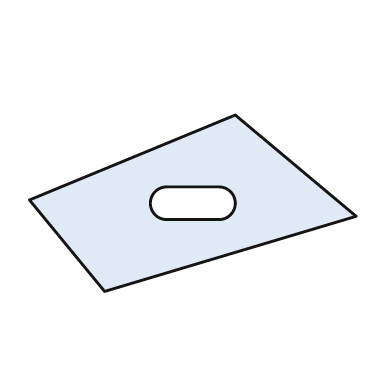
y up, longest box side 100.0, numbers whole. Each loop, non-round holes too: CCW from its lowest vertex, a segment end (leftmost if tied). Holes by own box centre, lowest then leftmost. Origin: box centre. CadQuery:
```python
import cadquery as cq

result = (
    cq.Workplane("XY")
    .moveTo(-27.0, -27.0)
    .lineTo(50.0, -4.0)
    .lineTo(13.0, 27.0)
    .lineTo(-50.0, 1.0)
    .close()
    .moveTo(-8.0, -5.0)
    .lineTo(8.0, -5.0)
    .threePointArc((13.0, 0.0), (8.0, 5.0))
    .lineTo(-8.0, 5.0)
    .threePointArc((-13.0, 0.0), (-8.0, -5.0))
    .close()
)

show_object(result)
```